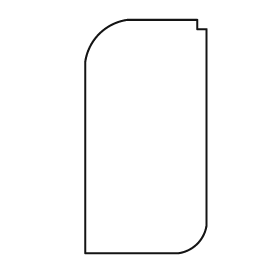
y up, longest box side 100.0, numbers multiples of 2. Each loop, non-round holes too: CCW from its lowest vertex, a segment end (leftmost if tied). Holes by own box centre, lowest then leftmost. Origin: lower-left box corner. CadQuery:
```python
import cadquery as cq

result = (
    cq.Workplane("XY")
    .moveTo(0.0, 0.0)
    .lineTo(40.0, 0.0)
    .threePointArc((48.0, 4.0), (52.0, 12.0))
    .lineTo(52.0, 96.0)
    .lineTo(48.0, 96.0)
    .lineTo(48.0, 100.0)
    .lineTo(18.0, 100.0)
    .threePointArc((6.0, 94.0), (0.0, 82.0))
    .close()
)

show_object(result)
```